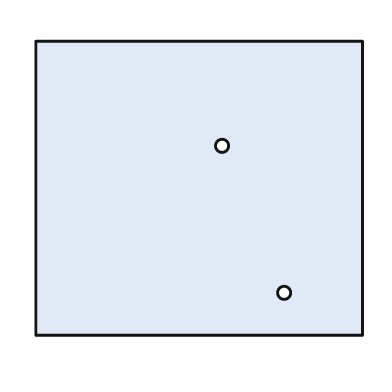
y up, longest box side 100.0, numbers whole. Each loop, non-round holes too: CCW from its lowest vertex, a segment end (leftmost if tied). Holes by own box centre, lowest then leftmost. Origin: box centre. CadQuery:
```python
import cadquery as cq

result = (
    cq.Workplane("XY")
    .moveTo(-50.0, -45.0)
    .lineTo(50.0, -45.0)
    .lineTo(50.0, 45.0)
    .lineTo(-50.0, 45.0)
    .close()
    .moveTo(26.0, -32.0)
    .circle(2.0)
    .moveTo(7.0, 13.0)
    .circle(2.0)
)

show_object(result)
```